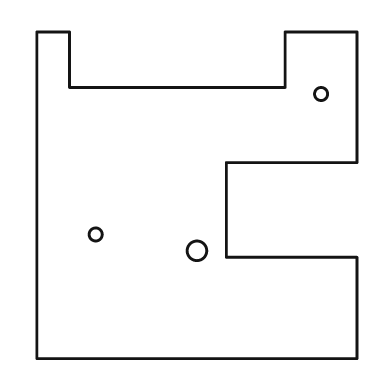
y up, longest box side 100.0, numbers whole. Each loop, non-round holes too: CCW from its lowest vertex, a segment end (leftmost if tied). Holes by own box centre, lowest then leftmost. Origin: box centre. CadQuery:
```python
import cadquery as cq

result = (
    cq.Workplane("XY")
    .moveTo(-49.0, -50.0)
    .lineTo(49.0, -50.0)
    .lineTo(49.0, -19.0)
    .lineTo(9.0, -19.0)
    .lineTo(9.0, 10.0)
    .lineTo(49.0, 10.0)
    .lineTo(49.0, 50.0)
    .lineTo(27.0, 50.0)
    .lineTo(27.0, 33.0)
    .lineTo(-39.0, 33.0)
    .lineTo(-39.0, 50.0)
    .lineTo(-49.0, 50.0)
    .close()
    .moveTo(0.0, -17.0)
    .circle(3.0)
    .moveTo(-31.0, -12.0)
    .circle(2.0)
    .moveTo(38.0, 31.0)
    .circle(2.0)
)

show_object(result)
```